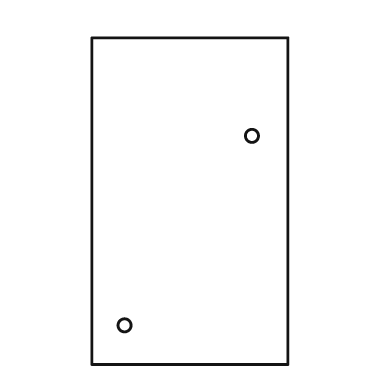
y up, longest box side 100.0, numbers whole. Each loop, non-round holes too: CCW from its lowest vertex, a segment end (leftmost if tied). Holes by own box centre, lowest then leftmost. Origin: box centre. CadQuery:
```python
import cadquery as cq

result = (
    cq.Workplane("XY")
    .moveTo(-30.0, -50.0)
    .lineTo(30.0, -50.0)
    .lineTo(30.0, 50.0)
    .lineTo(-30.0, 50.0)
    .close()
    .moveTo(-20.0, -38.0)
    .circle(2.0)
    .moveTo(19.0, 20.0)
    .circle(2.0)
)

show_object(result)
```